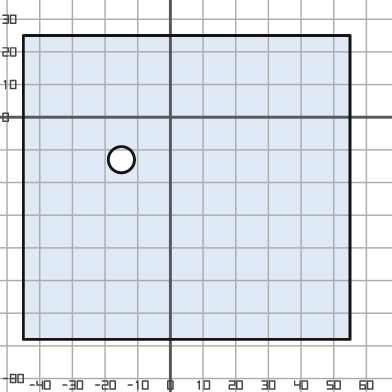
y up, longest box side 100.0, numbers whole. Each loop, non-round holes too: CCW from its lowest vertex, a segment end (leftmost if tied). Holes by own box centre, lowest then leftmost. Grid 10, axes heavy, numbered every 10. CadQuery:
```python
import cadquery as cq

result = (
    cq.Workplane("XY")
    .moveTo(-45.0, -68.0)
    .lineTo(55.0, -68.0)
    .lineTo(55.0, 25.0)
    .lineTo(-45.0, 25.0)
    .close()
    .moveTo(-15.0, -13.0)
    .circle(4.0)
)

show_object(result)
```